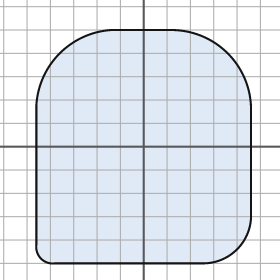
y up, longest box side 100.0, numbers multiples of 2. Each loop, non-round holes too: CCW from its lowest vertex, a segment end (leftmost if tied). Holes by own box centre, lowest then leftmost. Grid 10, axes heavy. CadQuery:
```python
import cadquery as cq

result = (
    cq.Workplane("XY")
    .moveTo(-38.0, -50.0)
    .lineTo(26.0, -50.0)
    .threePointArc((40.0, -44.0), (46.0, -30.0))
    .lineTo(46.0, 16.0)
    .threePointArc((36.0, 40.0), (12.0, 50.0))
    .lineTo(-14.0, 50.0)
    .threePointArc((-36.0, 40.0), (-46.0, 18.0))
    .lineTo(-46.0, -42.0)
    .threePointArc((-44.0, -48.0), (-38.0, -50.0))
    .close()
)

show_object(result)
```